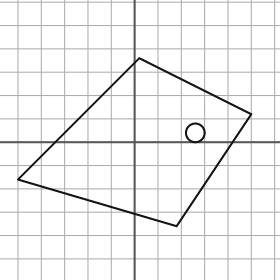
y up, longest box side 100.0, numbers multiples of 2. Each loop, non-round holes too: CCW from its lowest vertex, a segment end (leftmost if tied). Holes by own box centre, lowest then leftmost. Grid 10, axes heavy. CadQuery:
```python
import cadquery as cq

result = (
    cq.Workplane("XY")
    .moveTo(18.0, -36.0)
    .lineTo(50.0, 12.0)
    .lineTo(2.0, 36.0)
    .lineTo(-50.0, -16.0)
    .close()
    .moveTo(26.0, 4.0)
    .circle(4.0)
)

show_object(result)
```